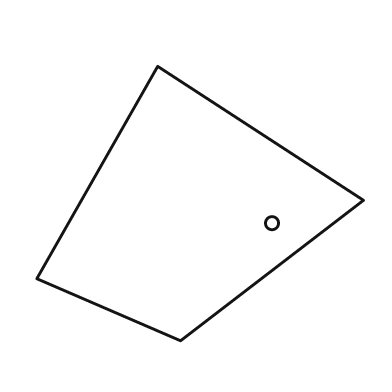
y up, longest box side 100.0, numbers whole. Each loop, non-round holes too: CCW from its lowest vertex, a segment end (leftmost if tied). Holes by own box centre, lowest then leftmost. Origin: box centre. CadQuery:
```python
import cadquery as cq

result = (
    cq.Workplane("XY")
    .moveTo(-6.0, -42.0)
    .lineTo(50.0, 1.0)
    .lineTo(-13.0, 42.0)
    .lineTo(-50.0, -23.0)
    .close()
    .moveTo(22.0, -6.0)
    .circle(2.0)
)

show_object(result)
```